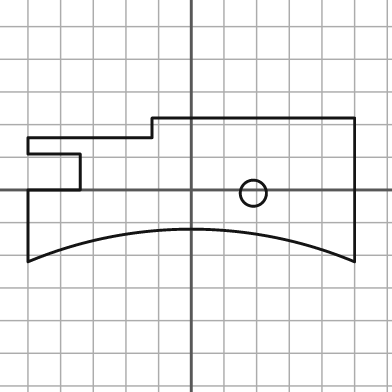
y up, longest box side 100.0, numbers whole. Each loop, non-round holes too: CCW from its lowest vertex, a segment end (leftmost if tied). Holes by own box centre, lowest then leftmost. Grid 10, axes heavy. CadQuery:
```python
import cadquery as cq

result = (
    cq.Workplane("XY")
    .moveTo(-50.0, -22.0)
    .threePointArc((0.0, -12.0), (50.0, -22.0))
    .lineTo(50.0, 22.0)
    .lineTo(-12.0, 22.0)
    .lineTo(-12.0, 16.0)
    .lineTo(-50.0, 16.0)
    .lineTo(-50.0, 11.0)
    .lineTo(-34.0, 11.0)
    .lineTo(-34.0, 0.0)
    .lineTo(-50.0, 0.0)
    .close()
    .moveTo(19.0, -1.0)
    .circle(4.0)
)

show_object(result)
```